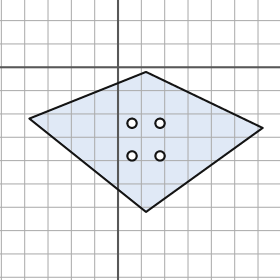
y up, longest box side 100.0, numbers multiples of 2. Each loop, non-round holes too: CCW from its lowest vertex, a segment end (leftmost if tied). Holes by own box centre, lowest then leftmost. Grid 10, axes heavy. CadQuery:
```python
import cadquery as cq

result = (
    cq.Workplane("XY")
    .moveTo(12.0, -62.0)
    .lineTo(62.0, -26.0)
    .lineTo(12.0, -2.0)
    .lineTo(-38.0, -22.0)
    .close()
    .moveTo(6.0, -38.0)
    .circle(2.0)
    .moveTo(18.0, -38.0)
    .circle(2.0)
    .moveTo(6.0, -24.0)
    .circle(2.0)
    .moveTo(18.0, -24.0)
    .circle(2.0)
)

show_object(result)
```